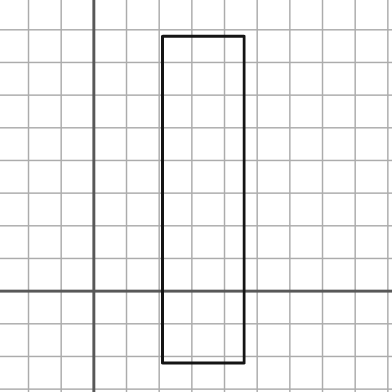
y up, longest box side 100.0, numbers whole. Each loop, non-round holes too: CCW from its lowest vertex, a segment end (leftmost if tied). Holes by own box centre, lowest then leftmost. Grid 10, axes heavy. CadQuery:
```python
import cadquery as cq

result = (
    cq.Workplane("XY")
    .moveTo(21.0, -22.0)
    .lineTo(46.0, -22.0)
    .lineTo(46.0, 78.0)
    .lineTo(21.0, 78.0)
    .close()
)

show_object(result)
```